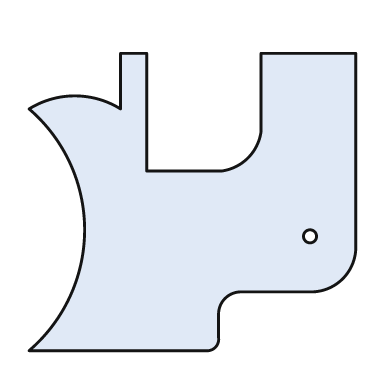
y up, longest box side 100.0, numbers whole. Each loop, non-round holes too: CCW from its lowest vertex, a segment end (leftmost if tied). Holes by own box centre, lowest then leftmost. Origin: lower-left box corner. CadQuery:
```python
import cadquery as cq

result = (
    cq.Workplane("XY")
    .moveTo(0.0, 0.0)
    .lineTo(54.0, 0.0)
    .threePointArc((57.0, 1.0), (58.0, 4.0))
    .lineTo(58.0, 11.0)
    .threePointArc((60.0, 16.0), (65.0, 18.0))
    .lineTo(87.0, 18.0)
    .threePointArc((96.0, 22.0), (100.0, 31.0))
    .lineTo(100.0, 91.0)
    .lineTo(71.0, 91.0)
    .lineTo(71.0, 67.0)
    .threePointArc((67.0, 59.0), (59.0, 55.0))
    .lineTo(36.0, 55.0)
    .lineTo(36.0, 91.0)
    .lineTo(28.0, 91.0)
    .lineTo(28.0, 74.0)
    .threePointArc((14.0, 78.0), (0.0, 74.0))
    .threePointArc((17.0, 37.0), (0.0, 0.0))
    .close()
    .moveTo(86.0, 35.0)
    .circle(2.0)
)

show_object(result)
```